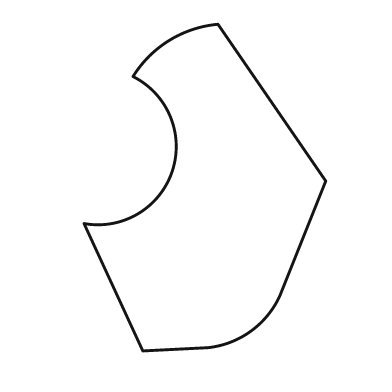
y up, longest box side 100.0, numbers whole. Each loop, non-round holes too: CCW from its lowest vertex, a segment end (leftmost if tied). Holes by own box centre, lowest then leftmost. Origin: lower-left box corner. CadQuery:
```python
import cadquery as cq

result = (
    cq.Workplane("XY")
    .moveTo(18.0, 0.0)
    .lineTo(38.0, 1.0)
    .threePointArc((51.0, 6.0), (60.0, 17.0))
    .lineTo(74.0, 52.0)
    .lineTo(41.0, 100.0)
    .threePointArc((26.0, 95.0), (15.0, 84.0))
    .threePointArc((27.0, 55.0), (0.0, 39.0))
    .close()
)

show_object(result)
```